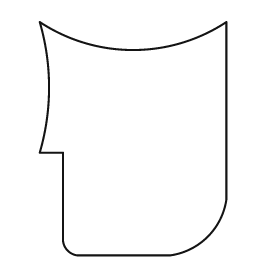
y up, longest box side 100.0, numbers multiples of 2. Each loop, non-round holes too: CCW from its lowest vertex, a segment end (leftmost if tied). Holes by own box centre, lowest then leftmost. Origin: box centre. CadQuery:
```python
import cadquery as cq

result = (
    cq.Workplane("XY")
    .moveTo(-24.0, -50.0)
    .lineTo(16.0, -50.0)
    .threePointArc((32.0, -42.0), (40.0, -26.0))
    .lineTo(40.0, 50.0)
    .threePointArc((0.0, 38.0), (-40.0, 50.0))
    .threePointArc((-36.0, 22.0), (-40.0, -6.0))
    .lineTo(-30.0, -6.0)
    .lineTo(-30.0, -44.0)
    .threePointArc((-28.0, -48.0), (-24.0, -50.0))
    .close()
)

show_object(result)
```